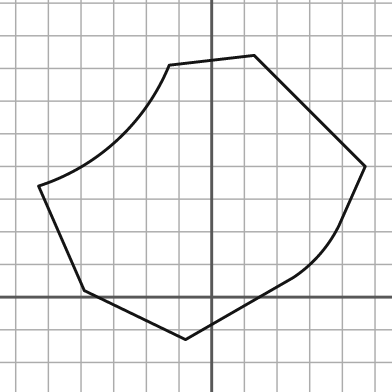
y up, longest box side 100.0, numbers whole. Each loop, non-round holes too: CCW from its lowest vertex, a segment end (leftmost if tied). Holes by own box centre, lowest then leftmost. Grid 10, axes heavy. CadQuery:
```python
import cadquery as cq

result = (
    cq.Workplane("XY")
    .moveTo(-8.0, -13.0)
    .lineTo(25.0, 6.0)
    .threePointArc((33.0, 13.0), (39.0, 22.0))
    .lineTo(47.0, 40.0)
    .lineTo(13.0, 74.0)
    .lineTo(-13.0, 71.0)
    .threePointArc((-29.0, 48.0), (-53.0, 34.0))
    .lineTo(-39.0, 2.0)
    .close()
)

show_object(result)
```